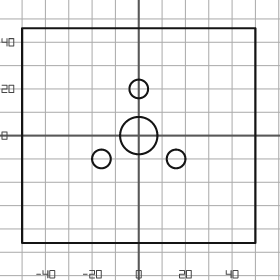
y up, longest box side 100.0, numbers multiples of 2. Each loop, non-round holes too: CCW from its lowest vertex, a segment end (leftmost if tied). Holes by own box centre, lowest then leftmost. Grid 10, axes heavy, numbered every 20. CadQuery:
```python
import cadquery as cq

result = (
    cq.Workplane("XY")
    .moveTo(-50.0, -46.0)
    .lineTo(50.0, -46.0)
    .lineTo(50.0, 46.0)
    .lineTo(-50.0, 46.0)
    .close()
    .moveTo(-16.0, -10.0)
    .circle(4.0)
    .moveTo(16.0, -10.0)
    .circle(4.0)
    .moveTo(0.0, 0.0)
    .circle(8.0)
    .moveTo(0.0, 20.0)
    .circle(4.0)
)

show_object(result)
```